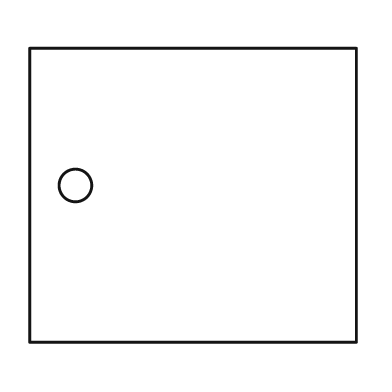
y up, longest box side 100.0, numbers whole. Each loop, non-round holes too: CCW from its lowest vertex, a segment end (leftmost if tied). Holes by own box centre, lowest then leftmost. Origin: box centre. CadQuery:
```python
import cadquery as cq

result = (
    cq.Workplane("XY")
    .moveTo(-50.0, -45.0)
    .lineTo(50.0, -45.0)
    .lineTo(50.0, 45.0)
    .lineTo(-50.0, 45.0)
    .close()
    .moveTo(-36.0, 3.0)
    .circle(5.0)
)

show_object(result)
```